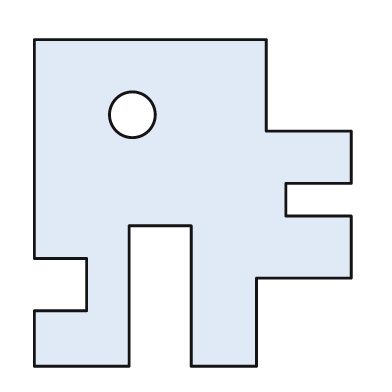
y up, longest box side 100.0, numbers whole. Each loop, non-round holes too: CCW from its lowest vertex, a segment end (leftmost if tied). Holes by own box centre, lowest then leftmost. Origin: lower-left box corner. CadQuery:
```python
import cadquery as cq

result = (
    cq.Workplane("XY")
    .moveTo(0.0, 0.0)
    .lineTo(29.0, 0.0)
    .lineTo(29.0, 43.0)
    .lineTo(48.0, 43.0)
    .lineTo(48.0, 0.0)
    .lineTo(68.0, 0.0)
    .lineTo(68.0, 27.0)
    .lineTo(97.0, 27.0)
    .lineTo(97.0, 46.0)
    .lineTo(77.0, 46.0)
    .lineTo(77.0, 56.0)
    .lineTo(97.0, 56.0)
    .lineTo(97.0, 72.0)
    .lineTo(71.0, 72.0)
    .lineTo(71.0, 100.0)
    .lineTo(0.0, 100.0)
    .lineTo(0.0, 33.0)
    .lineTo(16.0, 33.0)
    .lineTo(16.0, 17.0)
    .lineTo(0.0, 17.0)
    .close()
    .moveTo(30.0, 77.0)
    .circle(7.0)
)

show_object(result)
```